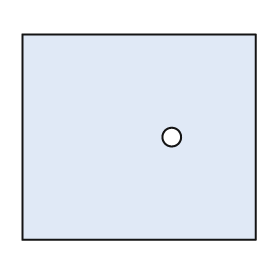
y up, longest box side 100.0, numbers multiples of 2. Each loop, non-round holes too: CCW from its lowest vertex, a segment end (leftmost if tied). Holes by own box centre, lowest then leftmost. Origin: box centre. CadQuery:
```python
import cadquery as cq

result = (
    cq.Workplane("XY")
    .moveTo(-50.0, -44.0)
    .lineTo(50.0, -44.0)
    .lineTo(50.0, 44.0)
    .lineTo(-50.0, 44.0)
    .close()
    .moveTo(14.0, 0.0)
    .circle(4.0)
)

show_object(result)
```